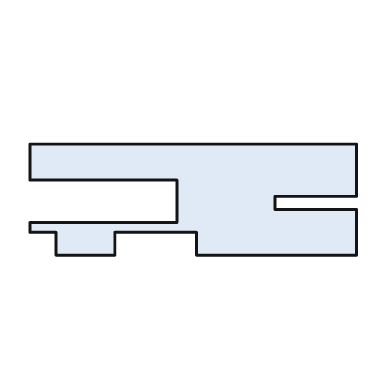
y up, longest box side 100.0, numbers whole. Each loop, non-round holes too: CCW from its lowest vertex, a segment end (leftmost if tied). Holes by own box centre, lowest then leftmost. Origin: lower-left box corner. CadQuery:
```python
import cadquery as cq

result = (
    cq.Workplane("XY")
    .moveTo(8.0, 0.0)
    .lineTo(26.0, 0.0)
    .lineTo(26.0, 7.0)
    .lineTo(51.0, 7.0)
    .lineTo(51.0, 0.0)
    .lineTo(100.0, 0.0)
    .lineTo(100.0, 14.0)
    .lineTo(75.0, 14.0)
    .lineTo(75.0, 18.0)
    .lineTo(100.0, 18.0)
    .lineTo(100.0, 34.0)
    .lineTo(0.0, 34.0)
    .lineTo(0.0, 23.0)
    .lineTo(45.0, 23.0)
    .lineTo(45.0, 10.0)
    .lineTo(0.0, 10.0)
    .lineTo(0.0, 7.0)
    .lineTo(8.0, 7.0)
    .close()
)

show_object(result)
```